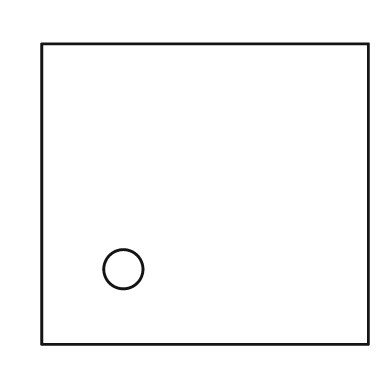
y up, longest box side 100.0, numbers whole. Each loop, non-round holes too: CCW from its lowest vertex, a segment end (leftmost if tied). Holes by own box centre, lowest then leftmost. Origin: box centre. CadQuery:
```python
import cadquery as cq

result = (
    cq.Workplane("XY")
    .moveTo(-50.0, -46.0)
    .lineTo(50.0, -46.0)
    .lineTo(50.0, 46.0)
    .lineTo(-50.0, 46.0)
    .close()
    .moveTo(-25.0, -23.0)
    .circle(6.0)
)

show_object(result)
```